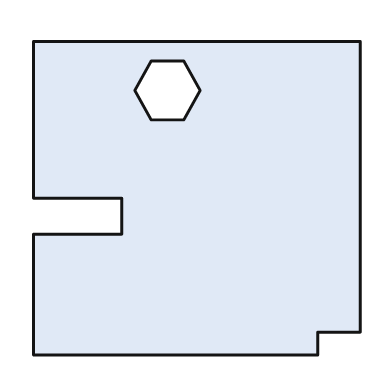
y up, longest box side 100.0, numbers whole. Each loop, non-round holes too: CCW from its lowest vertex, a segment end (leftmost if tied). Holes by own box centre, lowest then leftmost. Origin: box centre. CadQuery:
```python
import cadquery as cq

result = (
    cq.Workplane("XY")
    .moveTo(-50.0, -48.0)
    .lineTo(37.0, -48.0)
    .lineTo(37.0, -41.0)
    .lineTo(50.0, -41.0)
    .lineTo(50.0, 48.0)
    .lineTo(-50.0, 48.0)
    .lineTo(-50.0, 0.0)
    .lineTo(-23.0, 0.0)
    .lineTo(-23.0, -11.0)
    .lineTo(-50.0, -11.0)
    .close()
    .moveTo(-14.0, 24.0)
    .lineTo(-4.0, 24.0)
    .lineTo(1.0, 33.0)
    .lineTo(-4.0, 42.0)
    .lineTo(-14.0, 42.0)
    .lineTo(-19.0, 33.0)
    .close()
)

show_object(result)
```